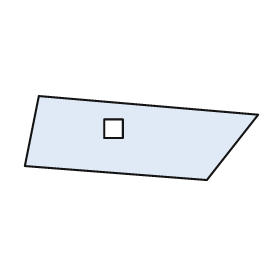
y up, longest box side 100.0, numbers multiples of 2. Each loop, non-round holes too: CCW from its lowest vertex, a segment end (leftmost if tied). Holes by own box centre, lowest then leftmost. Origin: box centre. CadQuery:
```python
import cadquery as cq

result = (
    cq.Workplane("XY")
    .moveTo(28.0, -18.0)
    .lineTo(50.0, 10.0)
    .lineTo(-44.0, 18.0)
    .lineTo(-50.0, -12.0)
    .close()
    .moveTo(-16.0, 0.0)
    .lineTo(-8.0, 0.0)
    .lineTo(-8.0, 8.0)
    .lineTo(-16.0, 8.0)
    .close()
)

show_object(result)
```